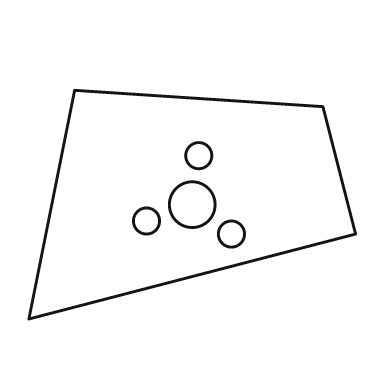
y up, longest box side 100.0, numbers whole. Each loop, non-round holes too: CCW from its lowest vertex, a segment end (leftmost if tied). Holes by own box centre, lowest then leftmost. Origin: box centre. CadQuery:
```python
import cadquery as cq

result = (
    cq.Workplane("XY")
    .moveTo(-50.0, -35.0)
    .lineTo(50.0, -9.0)
    .lineTo(40.0, 30.0)
    .lineTo(-36.0, 35.0)
    .close()
    .moveTo(12.0, -9.0)
    .circle(4.0)
    .moveTo(-14.0, -5.0)
    .circle(4.0)
    .moveTo(0.0, 0.0)
    .circle(7.0)
    .moveTo(2.0, 15.0)
    .circle(4.0)
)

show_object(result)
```